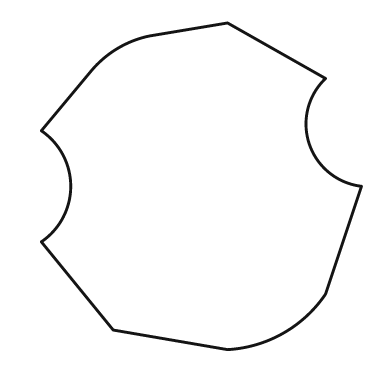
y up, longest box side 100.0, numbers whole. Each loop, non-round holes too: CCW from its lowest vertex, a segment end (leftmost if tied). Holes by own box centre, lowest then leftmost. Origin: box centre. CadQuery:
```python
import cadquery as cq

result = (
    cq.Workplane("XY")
    .moveTo(8.0, -50.0)
    .threePointArc((25.0, -45.0), (38.0, -33.0))
    .lineTo(49.0, 0.0)
    .threePointArc((33.0, 13.0), (38.0, 33.0))
    .lineTo(8.0, 50.0)
    .lineTo(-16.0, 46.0)
    .threePointArc((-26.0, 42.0), (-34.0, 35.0))
    .lineTo(-49.0, 17.0)
    .threePointArc((-40.0, 0.0), (-49.0, -17.0))
    .lineTo(-27.0, -44.0)
    .close()
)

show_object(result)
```